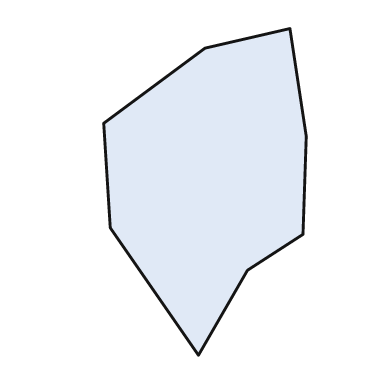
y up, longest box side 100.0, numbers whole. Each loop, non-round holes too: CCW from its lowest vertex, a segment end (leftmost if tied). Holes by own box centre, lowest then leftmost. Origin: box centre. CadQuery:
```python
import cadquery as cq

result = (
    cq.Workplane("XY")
    .moveTo(-2.0, -50.0)
    .lineTo(13.0, -24.0)
    .lineTo(30.0, -13.0)
    .lineTo(31.0, 17.0)
    .lineTo(26.0, 50.0)
    .lineTo(0.0, 44.0)
    .lineTo(-31.0, 21.0)
    .lineTo(-29.0, -11.0)
    .close()
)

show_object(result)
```